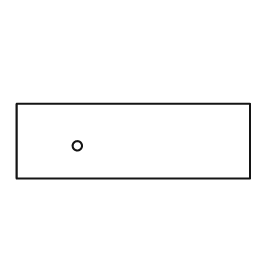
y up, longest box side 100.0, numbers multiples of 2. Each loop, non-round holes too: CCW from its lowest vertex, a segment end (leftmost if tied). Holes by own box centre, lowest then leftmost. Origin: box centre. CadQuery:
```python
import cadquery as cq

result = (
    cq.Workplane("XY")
    .moveTo(-50.0, -16.0)
    .lineTo(50.0, -16.0)
    .lineTo(50.0, 16.0)
    .lineTo(-50.0, 16.0)
    .close()
    .moveTo(-24.0, -2.0)
    .circle(2.0)
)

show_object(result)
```